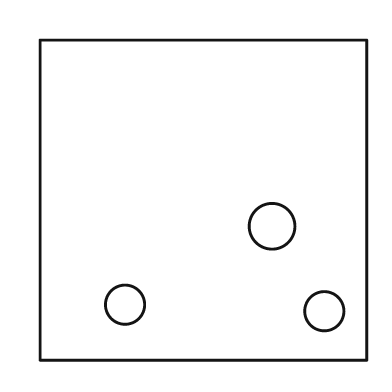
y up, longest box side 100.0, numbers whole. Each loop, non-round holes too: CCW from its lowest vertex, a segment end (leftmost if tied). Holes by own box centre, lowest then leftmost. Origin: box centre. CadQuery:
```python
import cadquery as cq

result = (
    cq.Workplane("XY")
    .moveTo(-50.0, -49.0)
    .lineTo(50.0, -49.0)
    .lineTo(50.0, 49.0)
    .lineTo(-50.0, 49.0)
    .close()
    .moveTo(37.0, -34.0)
    .circle(6.0)
    .moveTo(-24.0, -32.0)
    .circle(6.0)
    .moveTo(21.0, -8.0)
    .circle(7.0)
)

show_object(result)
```